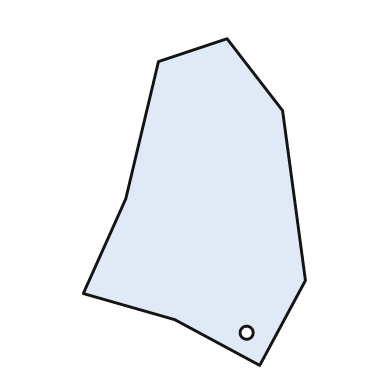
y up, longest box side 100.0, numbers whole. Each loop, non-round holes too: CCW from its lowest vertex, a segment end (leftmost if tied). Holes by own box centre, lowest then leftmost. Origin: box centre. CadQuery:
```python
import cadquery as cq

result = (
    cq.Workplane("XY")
    .moveTo(20.0, -50.0)
    .lineTo(34.0, -24.0)
    .lineTo(27.0, 28.0)
    .lineTo(10.0, 50.0)
    .lineTo(-11.0, 43.0)
    .lineTo(-21.0, 1.0)
    .lineTo(-34.0, -28.0)
    .lineTo(-6.0, -36.0)
    .close()
    .moveTo(16.0, -40.0)
    .circle(2.0)
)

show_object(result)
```